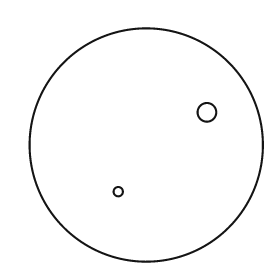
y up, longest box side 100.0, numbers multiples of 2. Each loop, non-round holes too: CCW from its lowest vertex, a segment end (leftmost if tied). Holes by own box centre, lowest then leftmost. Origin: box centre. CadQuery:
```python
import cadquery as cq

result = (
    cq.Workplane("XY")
    .moveTo(0.0, 0.0)
    .circle(50.0)
    .moveTo(-12.0, -20.0)
    .circle(2.0)
    .moveTo(26.0, 14.0)
    .circle(4.0)
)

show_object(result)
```